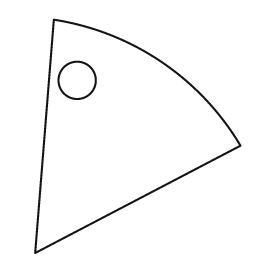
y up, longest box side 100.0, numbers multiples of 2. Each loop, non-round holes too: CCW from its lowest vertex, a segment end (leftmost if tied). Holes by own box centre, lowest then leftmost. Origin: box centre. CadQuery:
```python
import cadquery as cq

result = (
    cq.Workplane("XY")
    .moveTo(-44.0, -50.0)
    .lineTo(44.0, -4.0)
    .threePointArc((10.0, 32.0), (-36.0, 50.0))
    .close()
    .moveTo(-26.0, 24.0)
    .circle(8.0)
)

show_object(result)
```